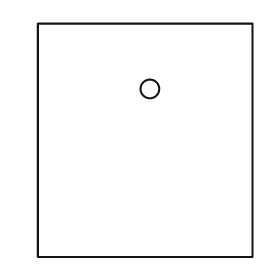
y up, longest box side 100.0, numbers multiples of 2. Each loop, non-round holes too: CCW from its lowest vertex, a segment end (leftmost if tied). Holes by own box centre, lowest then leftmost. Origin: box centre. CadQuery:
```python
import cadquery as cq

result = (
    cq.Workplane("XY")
    .moveTo(-46.0, -50.0)
    .lineTo(46.0, -50.0)
    .lineTo(46.0, 50.0)
    .lineTo(-46.0, 50.0)
    .close()
    .moveTo(2.0, 22.0)
    .circle(4.0)
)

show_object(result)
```